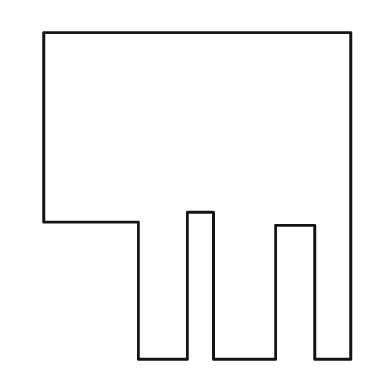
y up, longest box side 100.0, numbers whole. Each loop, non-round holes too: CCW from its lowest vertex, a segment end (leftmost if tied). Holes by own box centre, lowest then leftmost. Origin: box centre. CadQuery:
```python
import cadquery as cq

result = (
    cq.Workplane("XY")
    .moveTo(-18.0, -50.0)
    .lineTo(-3.0, -50.0)
    .lineTo(-3.0, -5.0)
    .lineTo(5.0, -5.0)
    .lineTo(5.0, -50.0)
    .lineTo(24.0, -50.0)
    .lineTo(24.0, -9.0)
    .lineTo(36.0, -9.0)
    .lineTo(36.0, -50.0)
    .lineTo(47.0, -50.0)
    .lineTo(47.0, 50.0)
    .lineTo(-47.0, 50.0)
    .lineTo(-47.0, -8.0)
    .lineTo(-18.0, -8.0)
    .close()
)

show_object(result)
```